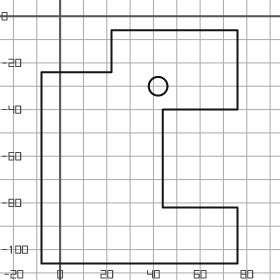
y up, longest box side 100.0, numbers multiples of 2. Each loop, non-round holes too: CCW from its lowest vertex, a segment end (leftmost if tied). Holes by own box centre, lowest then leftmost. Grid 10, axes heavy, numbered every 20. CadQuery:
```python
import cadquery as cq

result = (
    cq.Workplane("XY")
    .moveTo(-8.0, -106.0)
    .lineTo(76.0, -106.0)
    .lineTo(76.0, -82.0)
    .lineTo(44.0, -82.0)
    .lineTo(44.0, -40.0)
    .lineTo(76.0, -40.0)
    .lineTo(76.0, -6.0)
    .lineTo(22.0, -6.0)
    .lineTo(22.0, -24.0)
    .lineTo(-8.0, -24.0)
    .close()
    .moveTo(42.0, -30.0)
    .circle(4.0)
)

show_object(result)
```